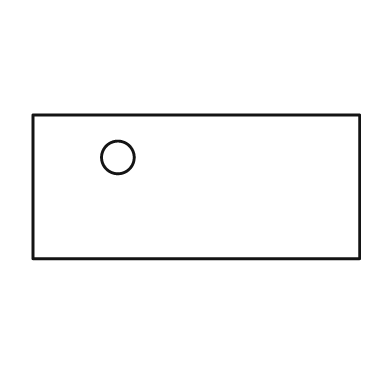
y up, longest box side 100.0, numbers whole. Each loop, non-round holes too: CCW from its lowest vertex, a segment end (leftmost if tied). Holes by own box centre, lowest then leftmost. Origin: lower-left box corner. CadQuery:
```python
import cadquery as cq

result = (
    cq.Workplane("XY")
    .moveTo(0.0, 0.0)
    .lineTo(100.0, 0.0)
    .lineTo(100.0, 44.0)
    .lineTo(0.0, 44.0)
    .close()
    .moveTo(26.0, 31.0)
    .circle(5.0)
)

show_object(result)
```